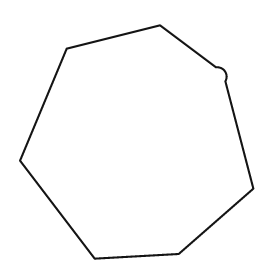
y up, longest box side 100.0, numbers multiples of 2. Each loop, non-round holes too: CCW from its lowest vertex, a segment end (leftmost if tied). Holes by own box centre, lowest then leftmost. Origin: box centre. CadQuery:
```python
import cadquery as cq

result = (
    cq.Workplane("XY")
    .moveTo(-18.0, -50.0)
    .lineTo(18.0, -48.0)
    .lineTo(50.0, -20.0)
    .lineTo(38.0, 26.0)
    .threePointArc((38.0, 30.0), (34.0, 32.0))
    .lineTo(10.0, 50.0)
    .lineTo(-30.0, 40.0)
    .lineTo(-50.0, -8.0)
    .close()
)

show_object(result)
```